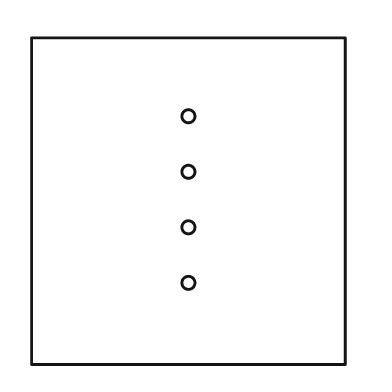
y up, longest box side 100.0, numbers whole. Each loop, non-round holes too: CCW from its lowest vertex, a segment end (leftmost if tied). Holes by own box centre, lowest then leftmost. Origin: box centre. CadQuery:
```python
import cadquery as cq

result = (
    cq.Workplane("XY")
    .moveTo(-48.0, -50.0)
    .lineTo(48.0, -50.0)
    .lineTo(48.0, 50.0)
    .lineTo(-48.0, 50.0)
    .close()
    .moveTo(0.0, -25.0)
    .circle(2.0)
    .moveTo(0.0, -8.0)
    .circle(2.0)
    .moveTo(0.0, 9.0)
    .circle(2.0)
    .moveTo(0.0, 26.0)
    .circle(2.0)
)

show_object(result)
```